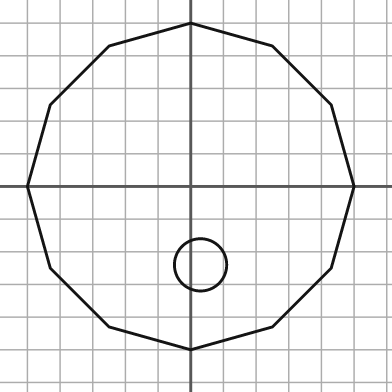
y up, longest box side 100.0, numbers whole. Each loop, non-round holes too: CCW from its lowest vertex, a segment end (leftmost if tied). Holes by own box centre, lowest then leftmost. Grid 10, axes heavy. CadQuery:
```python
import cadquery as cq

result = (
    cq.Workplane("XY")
    .moveTo(0.0, -50.0)
    .lineTo(25.0, -43.0)
    .lineTo(43.0, -25.0)
    .lineTo(50.0, 0.0)
    .lineTo(43.0, 25.0)
    .lineTo(25.0, 43.0)
    .lineTo(0.0, 50.0)
    .lineTo(-25.0, 43.0)
    .lineTo(-43.0, 25.0)
    .lineTo(-50.0, 0.0)
    .lineTo(-43.0, -25.0)
    .lineTo(-25.0, -43.0)
    .close()
    .moveTo(3.0, -24.0)
    .circle(8.0)
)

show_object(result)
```